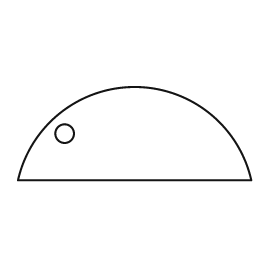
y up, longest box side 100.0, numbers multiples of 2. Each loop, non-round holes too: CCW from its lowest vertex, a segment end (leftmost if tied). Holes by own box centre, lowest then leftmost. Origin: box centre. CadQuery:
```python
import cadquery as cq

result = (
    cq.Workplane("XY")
    .moveTo(-50.0, -20.0)
    .lineTo(50.0, -20.0)
    .threePointArc((0.0, 20.0), (-50.0, -20.0))
    .close()
    .moveTo(-30.0, 0.0)
    .circle(4.0)
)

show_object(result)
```